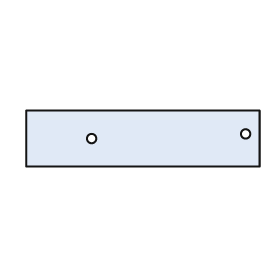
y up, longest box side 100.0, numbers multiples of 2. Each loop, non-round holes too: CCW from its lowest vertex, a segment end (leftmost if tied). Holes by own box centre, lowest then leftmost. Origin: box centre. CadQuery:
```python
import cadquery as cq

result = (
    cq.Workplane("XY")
    .moveTo(-50.0, -12.0)
    .lineTo(50.0, -12.0)
    .lineTo(50.0, 12.0)
    .lineTo(-50.0, 12.0)
    .close()
    .moveTo(-22.0, 0.0)
    .circle(2.0)
    .moveTo(44.0, 2.0)
    .circle(2.0)
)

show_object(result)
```